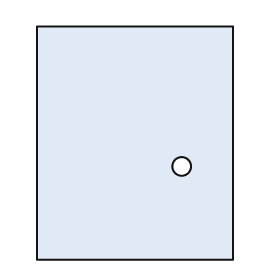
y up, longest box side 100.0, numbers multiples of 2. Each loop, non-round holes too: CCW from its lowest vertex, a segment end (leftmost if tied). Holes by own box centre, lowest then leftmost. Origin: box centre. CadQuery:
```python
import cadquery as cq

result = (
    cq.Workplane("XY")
    .moveTo(-42.0, -50.0)
    .lineTo(42.0, -50.0)
    .lineTo(42.0, 50.0)
    .lineTo(-42.0, 50.0)
    .close()
    .moveTo(20.0, -10.0)
    .circle(4.0)
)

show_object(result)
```